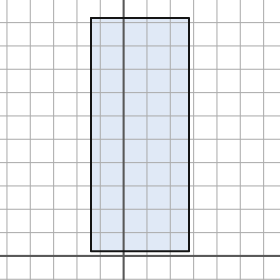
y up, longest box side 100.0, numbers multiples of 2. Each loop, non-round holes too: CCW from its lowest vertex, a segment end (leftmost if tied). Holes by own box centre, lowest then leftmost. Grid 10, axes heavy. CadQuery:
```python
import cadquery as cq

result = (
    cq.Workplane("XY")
    .moveTo(-14.0, 2.0)
    .lineTo(28.0, 2.0)
    .lineTo(28.0, 102.0)
    .lineTo(-14.0, 102.0)
    .close()
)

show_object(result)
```